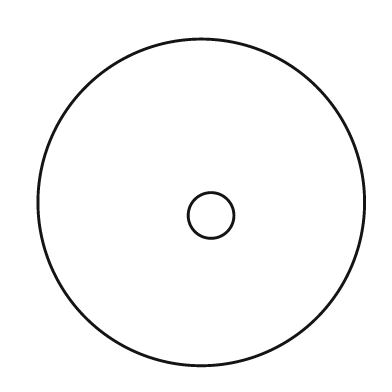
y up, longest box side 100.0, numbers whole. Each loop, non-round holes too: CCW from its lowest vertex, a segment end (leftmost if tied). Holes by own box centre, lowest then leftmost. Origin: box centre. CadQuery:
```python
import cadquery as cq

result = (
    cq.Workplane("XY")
    .moveTo(0.0, 0.0)
    .circle(50.0)
    .moveTo(3.0, -4.0)
    .circle(7.0)
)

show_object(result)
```